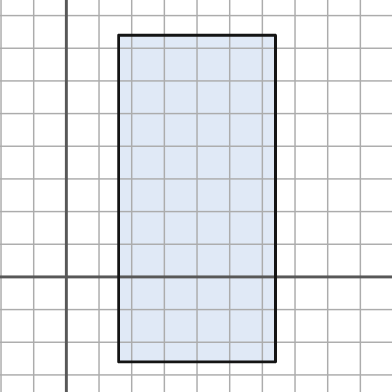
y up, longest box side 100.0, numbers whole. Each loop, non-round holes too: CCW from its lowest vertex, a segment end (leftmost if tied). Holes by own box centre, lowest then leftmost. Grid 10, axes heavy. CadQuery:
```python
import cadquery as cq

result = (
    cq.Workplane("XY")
    .moveTo(16.0, -26.0)
    .lineTo(64.0, -26.0)
    .lineTo(64.0, 74.0)
    .lineTo(16.0, 74.0)
    .close()
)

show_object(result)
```